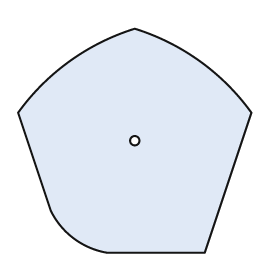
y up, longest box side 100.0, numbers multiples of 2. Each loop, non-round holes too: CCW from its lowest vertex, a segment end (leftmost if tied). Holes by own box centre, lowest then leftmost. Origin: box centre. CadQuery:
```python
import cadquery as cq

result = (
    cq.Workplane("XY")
    .moveTo(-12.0, -48.0)
    .lineTo(30.0, -48.0)
    .lineTo(50.0, 12.0)
    .threePointArc((28.0, 34.0), (0.0, 48.0))
    .threePointArc((-28.0, 34.0), (-50.0, 12.0))
    .lineTo(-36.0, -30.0)
    .threePointArc((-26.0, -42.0), (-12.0, -48.0))
    .close()
    .moveTo(0.0, 0.0)
    .circle(2.0)
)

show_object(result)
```